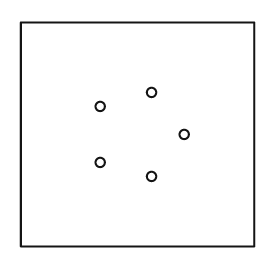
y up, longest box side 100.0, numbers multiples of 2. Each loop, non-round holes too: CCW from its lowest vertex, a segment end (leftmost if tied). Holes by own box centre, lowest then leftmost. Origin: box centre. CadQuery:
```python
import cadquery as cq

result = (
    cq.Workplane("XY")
    .moveTo(-50.0, -48.0)
    .lineTo(50.0, -48.0)
    .lineTo(50.0, 48.0)
    .lineTo(-50.0, 48.0)
    .close()
    .moveTo(6.0, -18.0)
    .circle(2.0)
    .moveTo(-16.0, -12.0)
    .circle(2.0)
    .moveTo(20.0, 0.0)
    .circle(2.0)
    .moveTo(-16.0, 12.0)
    .circle(2.0)
    .moveTo(6.0, 18.0)
    .circle(2.0)
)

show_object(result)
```